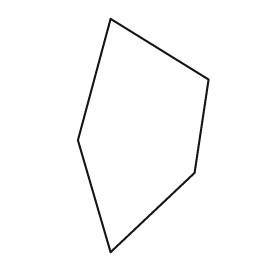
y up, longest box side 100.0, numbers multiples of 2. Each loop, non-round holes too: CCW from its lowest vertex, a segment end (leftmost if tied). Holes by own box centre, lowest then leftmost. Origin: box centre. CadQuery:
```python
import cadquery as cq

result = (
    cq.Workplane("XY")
    .moveTo(-14.0, -50.0)
    .lineTo(22.0, -16.0)
    .lineTo(28.0, 24.0)
    .lineTo(-14.0, 50.0)
    .lineTo(-28.0, -2.0)
    .close()
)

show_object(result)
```